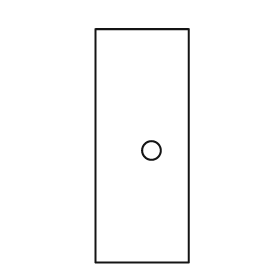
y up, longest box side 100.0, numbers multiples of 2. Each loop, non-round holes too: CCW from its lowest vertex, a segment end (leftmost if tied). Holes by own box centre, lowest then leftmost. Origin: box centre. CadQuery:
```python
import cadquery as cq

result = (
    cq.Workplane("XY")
    .moveTo(-20.0, -50.0)
    .lineTo(20.0, -50.0)
    .lineTo(20.0, 50.0)
    .lineTo(-20.0, 50.0)
    .close()
    .moveTo(4.0, -2.0)
    .circle(4.0)
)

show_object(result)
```